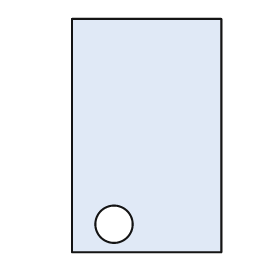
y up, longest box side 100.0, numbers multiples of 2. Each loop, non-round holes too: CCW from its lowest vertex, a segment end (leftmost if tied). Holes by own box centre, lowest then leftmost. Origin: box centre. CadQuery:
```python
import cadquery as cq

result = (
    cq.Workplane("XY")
    .moveTo(-32.0, -50.0)
    .lineTo(32.0, -50.0)
    .lineTo(32.0, 50.0)
    .lineTo(-32.0, 50.0)
    .close()
    .moveTo(-14.0, -38.0)
    .circle(8.0)
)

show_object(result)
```